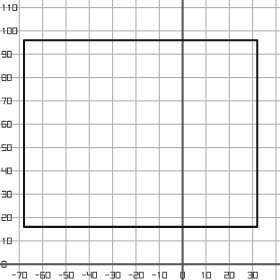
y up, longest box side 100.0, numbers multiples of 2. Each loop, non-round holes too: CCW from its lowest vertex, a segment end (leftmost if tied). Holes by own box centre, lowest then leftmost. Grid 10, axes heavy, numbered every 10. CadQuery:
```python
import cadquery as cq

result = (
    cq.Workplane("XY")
    .moveTo(-68.0, 16.0)
    .lineTo(32.0, 16.0)
    .lineTo(32.0, 96.0)
    .lineTo(-68.0, 96.0)
    .close()
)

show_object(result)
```